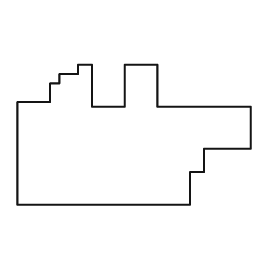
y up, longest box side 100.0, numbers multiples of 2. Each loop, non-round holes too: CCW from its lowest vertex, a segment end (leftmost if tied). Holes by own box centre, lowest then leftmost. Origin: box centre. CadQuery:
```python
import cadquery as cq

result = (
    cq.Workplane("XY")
    .moveTo(-50.0, -30.0)
    .lineTo(24.0, -30.0)
    .lineTo(24.0, -16.0)
    .lineTo(30.0, -16.0)
    .lineTo(30.0, -6.0)
    .lineTo(50.0, -6.0)
    .lineTo(50.0, 12.0)
    .lineTo(10.0, 12.0)
    .lineTo(10.0, 30.0)
    .lineTo(-4.0, 30.0)
    .lineTo(-4.0, 12.0)
    .lineTo(-18.0, 12.0)
    .lineTo(-18.0, 30.0)
    .lineTo(-24.0, 30.0)
    .lineTo(-24.0, 26.0)
    .lineTo(-32.0, 26.0)
    .lineTo(-32.0, 22.0)
    .lineTo(-36.0, 22.0)
    .lineTo(-36.0, 14.0)
    .lineTo(-50.0, 14.0)
    .close()
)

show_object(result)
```